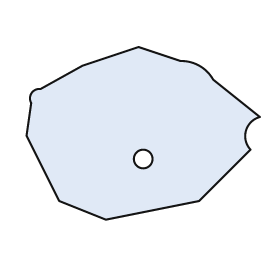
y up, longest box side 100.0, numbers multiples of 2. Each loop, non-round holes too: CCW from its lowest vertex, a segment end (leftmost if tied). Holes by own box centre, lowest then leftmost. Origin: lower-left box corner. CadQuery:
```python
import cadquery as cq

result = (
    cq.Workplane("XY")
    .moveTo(34.0, 0.0)
    .lineTo(74.0, 8.0)
    .lineTo(96.0, 30.0)
    .threePointArc((94.0, 38.0), (100.0, 44.0))
    .lineTo(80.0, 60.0)
    .threePointArc((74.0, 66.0), (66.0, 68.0))
    .lineTo(48.0, 74.0)
    .lineTo(24.0, 66.0)
    .lineTo(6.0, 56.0)
    .threePointArc((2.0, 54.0), (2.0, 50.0))
    .lineTo(0.0, 36.0)
    .lineTo(14.0, 8.0)
    .close()
    .moveTo(50.0, 26.0)
    .circle(4.0)
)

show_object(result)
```